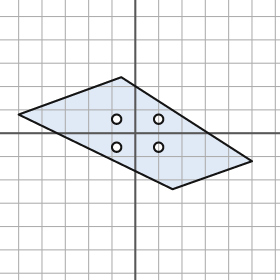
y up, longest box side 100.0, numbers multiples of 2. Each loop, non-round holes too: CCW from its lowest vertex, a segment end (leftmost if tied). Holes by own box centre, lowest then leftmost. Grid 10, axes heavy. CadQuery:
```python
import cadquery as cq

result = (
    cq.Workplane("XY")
    .moveTo(16.0, -24.0)
    .lineTo(50.0, -12.0)
    .lineTo(-6.0, 24.0)
    .lineTo(-50.0, 8.0)
    .close()
    .moveTo(-8.0, -6.0)
    .circle(2.0)
    .moveTo(10.0, -6.0)
    .circle(2.0)
    .moveTo(-8.0, 6.0)
    .circle(2.0)
    .moveTo(10.0, 6.0)
    .circle(2.0)
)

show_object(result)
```